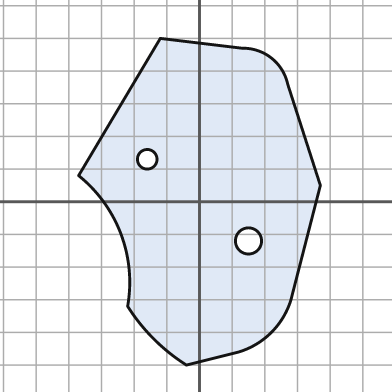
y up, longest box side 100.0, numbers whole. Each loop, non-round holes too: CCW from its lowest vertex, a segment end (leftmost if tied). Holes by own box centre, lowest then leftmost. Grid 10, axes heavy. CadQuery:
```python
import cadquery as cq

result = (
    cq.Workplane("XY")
    .moveTo(-4.0, -50.0)
    .lineTo(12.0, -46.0)
    .threePointArc((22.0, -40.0), (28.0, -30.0))
    .lineTo(37.0, 5.0)
    .lineTo(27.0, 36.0)
    .threePointArc((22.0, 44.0), (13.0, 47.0))
    .lineTo(-12.0, 50.0)
    .lineTo(-37.0, 8.0)
    .threePointArc((-24.0, -10.0), (-22.0, -32.0))
    .threePointArc((-14.0, -42.0), (-4.0, -50.0))
    .close()
    .moveTo(15.0, -12.0)
    .circle(4.0)
    .moveTo(-16.0, 13.0)
    .circle(3.0)
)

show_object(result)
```